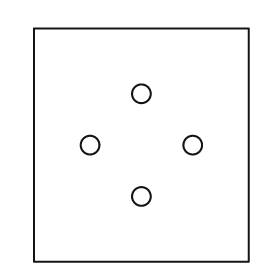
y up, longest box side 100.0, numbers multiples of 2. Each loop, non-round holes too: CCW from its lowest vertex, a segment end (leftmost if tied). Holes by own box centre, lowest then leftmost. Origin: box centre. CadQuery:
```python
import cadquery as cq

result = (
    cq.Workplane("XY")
    .moveTo(-46.0, -50.0)
    .lineTo(46.0, -50.0)
    .lineTo(46.0, 50.0)
    .lineTo(-46.0, 50.0)
    .close()
    .moveTo(0.0, -22.0)
    .circle(4.0)
    .moveTo(-22.0, 0.0)
    .circle(4.0)
    .moveTo(22.0, 0.0)
    .circle(4.0)
    .moveTo(0.0, 22.0)
    .circle(4.0)
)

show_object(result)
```